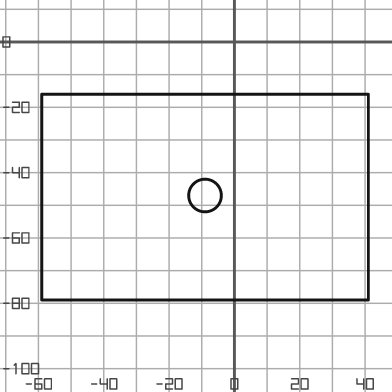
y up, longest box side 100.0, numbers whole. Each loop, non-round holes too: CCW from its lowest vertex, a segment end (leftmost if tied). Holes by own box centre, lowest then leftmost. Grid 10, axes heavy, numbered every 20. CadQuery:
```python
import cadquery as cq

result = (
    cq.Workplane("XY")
    .moveTo(-59.0, -79.0)
    .lineTo(41.0, -79.0)
    .lineTo(41.0, -16.0)
    .lineTo(-59.0, -16.0)
    .close()
    .moveTo(-9.0, -47.0)
    .circle(5.0)
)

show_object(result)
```